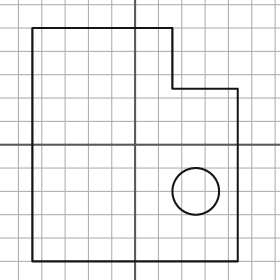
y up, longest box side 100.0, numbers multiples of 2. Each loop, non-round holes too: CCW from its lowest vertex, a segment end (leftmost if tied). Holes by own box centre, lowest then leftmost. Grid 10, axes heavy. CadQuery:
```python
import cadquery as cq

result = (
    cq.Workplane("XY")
    .moveTo(-44.0, -50.0)
    .lineTo(44.0, -50.0)
    .lineTo(44.0, 24.0)
    .lineTo(16.0, 24.0)
    .lineTo(16.0, 50.0)
    .lineTo(-44.0, 50.0)
    .close()
    .moveTo(26.0, -20.0)
    .circle(10.0)
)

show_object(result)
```